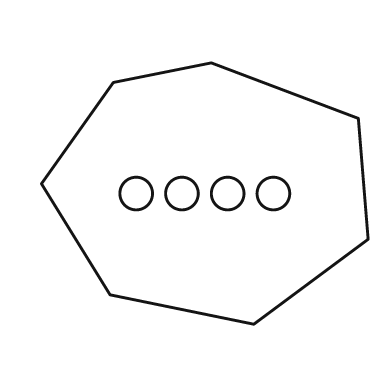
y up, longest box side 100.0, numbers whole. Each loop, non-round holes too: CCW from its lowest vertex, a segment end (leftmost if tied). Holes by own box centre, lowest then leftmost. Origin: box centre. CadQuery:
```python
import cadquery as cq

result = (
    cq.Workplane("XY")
    .moveTo(15.0, -40.0)
    .lineTo(50.0, -14.0)
    .lineTo(47.0, 23.0)
    .lineTo(2.0, 40.0)
    .lineTo(-28.0, 34.0)
    .lineTo(-50.0, 3.0)
    .lineTo(-29.0, -31.0)
    .close()
    .moveTo(-21.0, 0.0)
    .circle(5.0)
    .moveTo(-7.0, 0.0)
    .circle(5.0)
    .moveTo(7.0, 0.0)
    .circle(5.0)
    .moveTo(21.0, 0.0)
    .circle(5.0)
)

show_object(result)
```